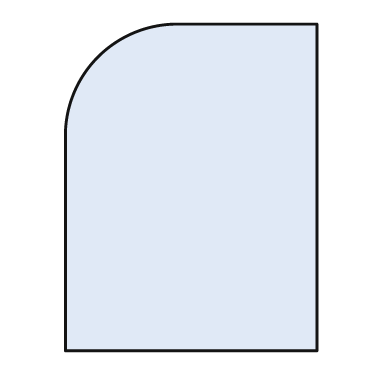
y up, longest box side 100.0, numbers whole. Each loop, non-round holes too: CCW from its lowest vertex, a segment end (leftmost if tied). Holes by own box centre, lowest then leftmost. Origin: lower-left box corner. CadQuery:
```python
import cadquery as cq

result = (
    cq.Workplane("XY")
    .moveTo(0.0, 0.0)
    .lineTo(77.0, 0.0)
    .lineTo(77.0, 100.0)
    .lineTo(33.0, 100.0)
    .threePointArc((10.0, 90.0), (0.0, 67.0))
    .close()
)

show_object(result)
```